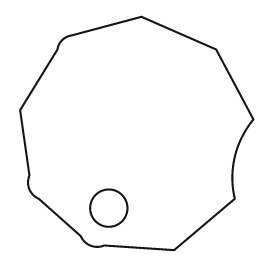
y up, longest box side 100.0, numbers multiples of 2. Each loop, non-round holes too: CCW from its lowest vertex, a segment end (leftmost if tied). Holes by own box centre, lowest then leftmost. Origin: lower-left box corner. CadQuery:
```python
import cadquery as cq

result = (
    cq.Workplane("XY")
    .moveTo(66.0, 0.0)
    .lineTo(92.0, 22.0)
    .threePointArc((92.0, 40.0), (100.0, 56.0))
    .lineTo(84.0, 86.0)
    .lineTo(52.0, 100.0)
    .lineTo(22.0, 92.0)
    .threePointArc((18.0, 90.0), (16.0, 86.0))
    .lineTo(0.0, 60.0)
    .lineTo(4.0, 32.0)
    .threePointArc((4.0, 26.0), (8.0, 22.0))
    .lineTo(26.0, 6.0)
    .threePointArc((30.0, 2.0), (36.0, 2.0))
    .close()
    .moveTo(38.0, 18.0)
    .circle(8.0)
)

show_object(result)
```